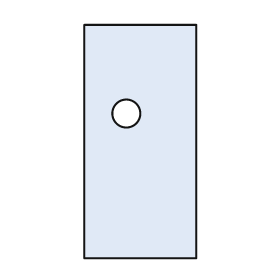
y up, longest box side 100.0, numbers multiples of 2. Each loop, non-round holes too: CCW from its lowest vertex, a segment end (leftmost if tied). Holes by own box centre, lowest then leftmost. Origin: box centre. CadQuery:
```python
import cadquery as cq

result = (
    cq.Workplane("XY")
    .moveTo(-24.0, -50.0)
    .lineTo(24.0, -50.0)
    .lineTo(24.0, 50.0)
    .lineTo(-24.0, 50.0)
    .close()
    .moveTo(-6.0, 12.0)
    .circle(6.0)
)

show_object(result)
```